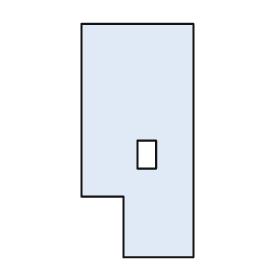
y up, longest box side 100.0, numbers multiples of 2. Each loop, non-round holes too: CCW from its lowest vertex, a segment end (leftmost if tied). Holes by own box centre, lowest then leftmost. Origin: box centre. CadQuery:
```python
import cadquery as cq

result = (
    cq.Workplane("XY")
    .moveTo(-6.0, -50.0)
    .lineTo(24.0, -50.0)
    .lineTo(24.0, 50.0)
    .lineTo(-24.0, 50.0)
    .lineTo(-24.0, -24.0)
    .lineTo(-6.0, -24.0)
    .close()
    .moveTo(0.0, -12.0)
    .lineTo(8.0, -12.0)
    .lineTo(8.0, 0.0)
    .lineTo(0.0, 0.0)
    .close()
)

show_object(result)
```